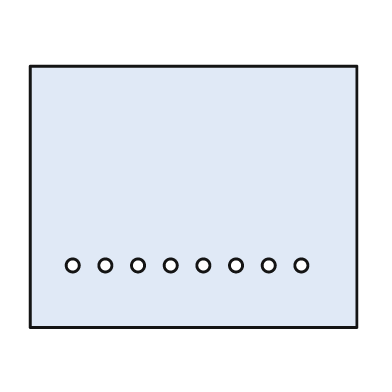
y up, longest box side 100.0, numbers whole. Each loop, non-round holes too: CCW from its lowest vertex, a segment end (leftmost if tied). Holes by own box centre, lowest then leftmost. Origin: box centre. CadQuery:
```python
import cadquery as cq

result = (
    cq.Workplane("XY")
    .moveTo(-50.0, -40.0)
    .lineTo(50.0, -40.0)
    .lineTo(50.0, 40.0)
    .lineTo(-50.0, 40.0)
    .close()
    .moveTo(-37.0, -21.0)
    .circle(2.0)
    .moveTo(-27.0, -21.0)
    .circle(2.0)
    .moveTo(-17.0, -21.0)
    .circle(2.0)
    .moveTo(-7.0, -21.0)
    .circle(2.0)
    .moveTo(3.0, -21.0)
    .circle(2.0)
    .moveTo(13.0, -21.0)
    .circle(2.0)
    .moveTo(23.0, -21.0)
    .circle(2.0)
    .moveTo(33.0, -21.0)
    .circle(2.0)
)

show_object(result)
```